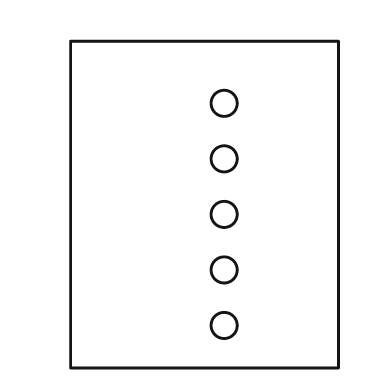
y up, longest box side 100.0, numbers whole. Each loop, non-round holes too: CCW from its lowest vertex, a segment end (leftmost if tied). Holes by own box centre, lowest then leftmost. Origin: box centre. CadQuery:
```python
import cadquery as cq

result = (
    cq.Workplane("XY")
    .moveTo(-41.0, -50.0)
    .lineTo(41.0, -50.0)
    .lineTo(41.0, 50.0)
    .lineTo(-41.0, 50.0)
    .close()
    .moveTo(6.0, -37.0)
    .circle(4.0)
    .moveTo(6.0, -20.0)
    .circle(4.0)
    .moveTo(6.0, -3.0)
    .circle(4.0)
    .moveTo(6.0, 14.0)
    .circle(4.0)
    .moveTo(6.0, 31.0)
    .circle(4.0)
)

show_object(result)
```